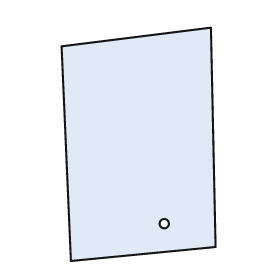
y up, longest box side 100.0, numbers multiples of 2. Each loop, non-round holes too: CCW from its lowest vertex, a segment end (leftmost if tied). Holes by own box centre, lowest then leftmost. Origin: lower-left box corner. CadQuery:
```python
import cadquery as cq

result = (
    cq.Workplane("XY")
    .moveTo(4.0, 0.0)
    .lineTo(66.0, 6.0)
    .lineTo(64.0, 100.0)
    .lineTo(0.0, 92.0)
    .close()
    .moveTo(44.0, 16.0)
    .circle(2.0)
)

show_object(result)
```